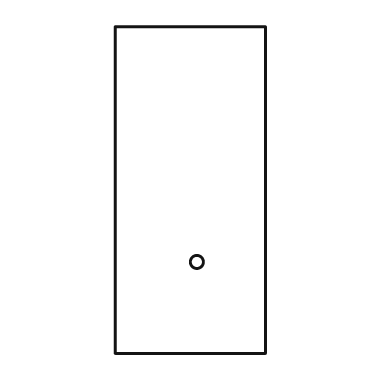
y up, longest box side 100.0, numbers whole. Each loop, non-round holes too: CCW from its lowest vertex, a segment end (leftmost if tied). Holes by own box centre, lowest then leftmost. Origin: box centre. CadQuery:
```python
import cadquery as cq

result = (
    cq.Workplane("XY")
    .moveTo(-23.0, -50.0)
    .lineTo(23.0, -50.0)
    .lineTo(23.0, 50.0)
    .lineTo(-23.0, 50.0)
    .close()
    .moveTo(2.0, -22.0)
    .circle(2.0)
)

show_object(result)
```